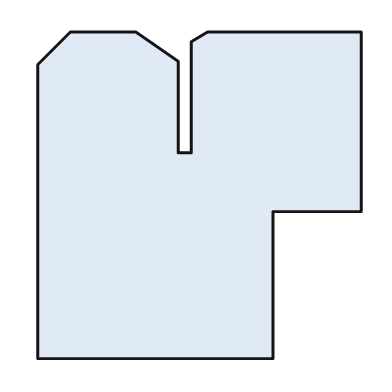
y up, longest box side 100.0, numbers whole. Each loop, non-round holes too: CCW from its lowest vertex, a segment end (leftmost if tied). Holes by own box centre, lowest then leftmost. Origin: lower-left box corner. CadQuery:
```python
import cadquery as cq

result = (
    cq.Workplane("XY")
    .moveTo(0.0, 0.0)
    .lineTo(72.0, 0.0)
    .lineTo(72.0, 45.0)
    .lineTo(99.0, 45.0)
    .lineTo(99.0, 100.0)
    .lineTo(52.0, 100.0)
    .lineTo(47.0, 97.0)
    .lineTo(47.0, 63.0)
    .lineTo(43.0, 63.0)
    .lineTo(43.0, 91.0)
    .lineTo(30.0, 100.0)
    .lineTo(10.0, 100.0)
    .lineTo(0.0, 90.0)
    .close()
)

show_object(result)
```